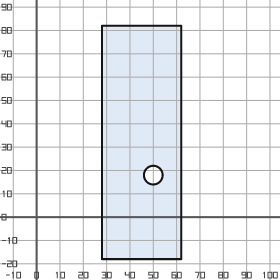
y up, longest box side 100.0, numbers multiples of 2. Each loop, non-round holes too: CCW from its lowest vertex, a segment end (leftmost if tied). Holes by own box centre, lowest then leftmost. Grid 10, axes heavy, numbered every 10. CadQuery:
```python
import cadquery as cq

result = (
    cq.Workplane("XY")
    .moveTo(28.0, -18.0)
    .lineTo(62.0, -18.0)
    .lineTo(62.0, 82.0)
    .lineTo(28.0, 82.0)
    .close()
    .moveTo(50.0, 18.0)
    .circle(4.0)
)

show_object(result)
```